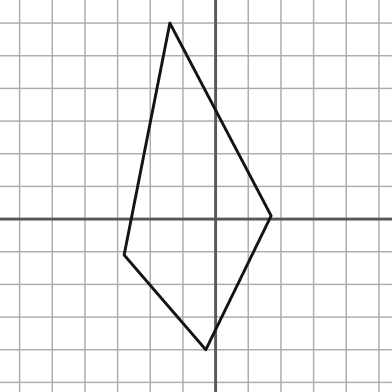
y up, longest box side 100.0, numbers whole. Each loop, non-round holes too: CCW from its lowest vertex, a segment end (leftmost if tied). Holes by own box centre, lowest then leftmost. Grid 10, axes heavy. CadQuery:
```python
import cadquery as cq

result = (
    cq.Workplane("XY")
    .moveTo(-3.0, -40.0)
    .lineTo(17.0, 1.0)
    .lineTo(-14.0, 60.0)
    .lineTo(-28.0, -11.0)
    .close()
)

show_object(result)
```